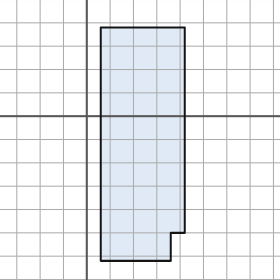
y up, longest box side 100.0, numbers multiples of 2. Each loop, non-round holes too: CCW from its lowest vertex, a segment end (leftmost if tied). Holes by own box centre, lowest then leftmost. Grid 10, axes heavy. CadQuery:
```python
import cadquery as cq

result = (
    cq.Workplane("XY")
    .moveTo(6.0, -62.0)
    .lineTo(36.0, -62.0)
    .lineTo(36.0, -50.0)
    .lineTo(42.0, -50.0)
    .lineTo(42.0, 38.0)
    .lineTo(6.0, 38.0)
    .close()
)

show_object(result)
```